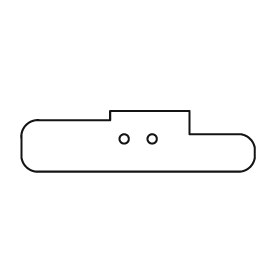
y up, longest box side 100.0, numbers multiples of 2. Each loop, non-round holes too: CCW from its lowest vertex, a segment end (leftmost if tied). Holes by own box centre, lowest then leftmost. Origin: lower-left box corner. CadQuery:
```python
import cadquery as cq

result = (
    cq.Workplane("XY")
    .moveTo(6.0, 0.0)
    .lineTo(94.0, 0.0)
    .threePointArc((98.0, 2.0), (100.0, 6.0))
    .lineTo(100.0, 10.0)
    .threePointArc((98.0, 14.0), (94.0, 16.0))
    .lineTo(72.0, 16.0)
    .lineTo(72.0, 26.0)
    .lineTo(38.0, 26.0)
    .lineTo(38.0, 22.0)
    .lineTo(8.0, 22.0)
    .threePointArc((2.0, 20.0), (0.0, 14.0))
    .lineTo(0.0, 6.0)
    .threePointArc((2.0, 2.0), (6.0, 0.0))
    .close()
    .moveTo(44.0, 14.0)
    .circle(2.0)
    .moveTo(56.0, 14.0)
    .circle(2.0)
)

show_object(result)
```